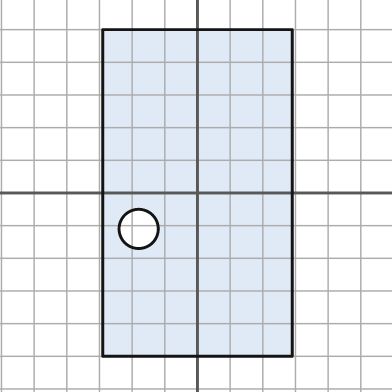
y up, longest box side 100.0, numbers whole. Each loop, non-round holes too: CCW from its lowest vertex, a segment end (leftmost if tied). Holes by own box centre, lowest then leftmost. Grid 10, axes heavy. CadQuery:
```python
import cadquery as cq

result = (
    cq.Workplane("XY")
    .moveTo(-29.0, -50.0)
    .lineTo(29.0, -50.0)
    .lineTo(29.0, 50.0)
    .lineTo(-29.0, 50.0)
    .close()
    .moveTo(-18.0, -11.0)
    .circle(6.0)
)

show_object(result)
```